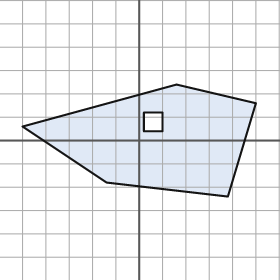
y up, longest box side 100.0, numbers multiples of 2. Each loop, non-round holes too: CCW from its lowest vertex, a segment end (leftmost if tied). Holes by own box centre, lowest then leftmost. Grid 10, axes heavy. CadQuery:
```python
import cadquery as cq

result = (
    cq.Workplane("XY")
    .moveTo(38.0, -24.0)
    .lineTo(50.0, 16.0)
    .lineTo(16.0, 24.0)
    .lineTo(-50.0, 6.0)
    .lineTo(-14.0, -18.0)
    .close()
    .moveTo(2.0, 4.0)
    .lineTo(10.0, 4.0)
    .lineTo(10.0, 12.0)
    .lineTo(2.0, 12.0)
    .close()
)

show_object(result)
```